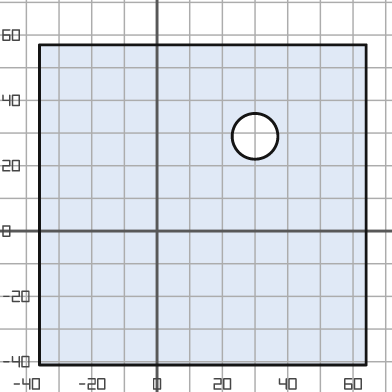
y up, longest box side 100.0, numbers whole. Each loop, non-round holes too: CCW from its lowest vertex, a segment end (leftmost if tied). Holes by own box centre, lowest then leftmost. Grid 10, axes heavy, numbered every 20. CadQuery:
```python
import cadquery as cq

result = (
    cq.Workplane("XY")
    .moveTo(-36.0, -41.0)
    .lineTo(64.0, -41.0)
    .lineTo(64.0, 57.0)
    .lineTo(-36.0, 57.0)
    .close()
    .moveTo(30.0, 29.0)
    .circle(7.0)
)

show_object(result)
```